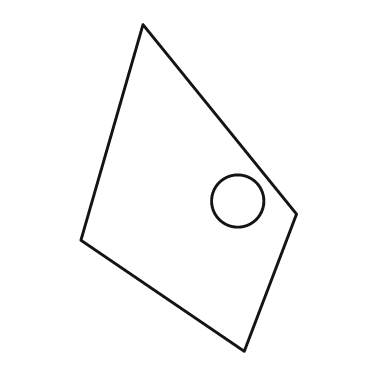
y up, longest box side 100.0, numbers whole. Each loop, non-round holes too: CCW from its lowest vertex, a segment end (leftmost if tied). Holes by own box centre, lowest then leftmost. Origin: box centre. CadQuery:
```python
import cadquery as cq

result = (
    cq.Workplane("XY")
    .moveTo(17.0, -50.0)
    .lineTo(33.0, -8.0)
    .lineTo(-14.0, 50.0)
    .lineTo(-33.0, -16.0)
    .close()
    .moveTo(15.0, -4.0)
    .circle(8.0)
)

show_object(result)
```